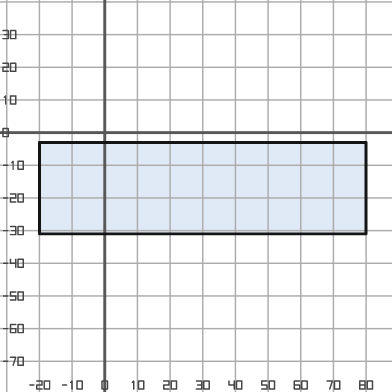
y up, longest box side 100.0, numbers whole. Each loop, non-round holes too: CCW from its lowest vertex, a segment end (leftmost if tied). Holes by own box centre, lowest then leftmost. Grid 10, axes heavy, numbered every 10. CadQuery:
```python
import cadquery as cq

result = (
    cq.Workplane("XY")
    .moveTo(-20.0, -31.0)
    .lineTo(80.0, -31.0)
    .lineTo(80.0, -3.0)
    .lineTo(-20.0, -3.0)
    .close()
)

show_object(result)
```